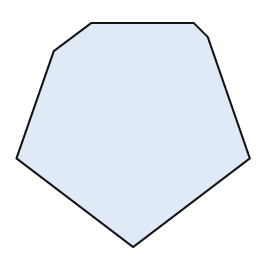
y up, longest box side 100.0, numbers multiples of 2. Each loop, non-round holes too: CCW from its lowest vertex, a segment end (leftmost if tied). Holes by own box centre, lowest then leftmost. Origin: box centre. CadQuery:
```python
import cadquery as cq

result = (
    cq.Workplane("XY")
    .moveTo(0.0, -48.0)
    .lineTo(50.0, -10.0)
    .lineTo(32.0, 42.0)
    .lineTo(26.0, 48.0)
    .lineTo(-18.0, 48.0)
    .lineTo(-34.0, 36.0)
    .lineTo(-50.0, -10.0)
    .close()
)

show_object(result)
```